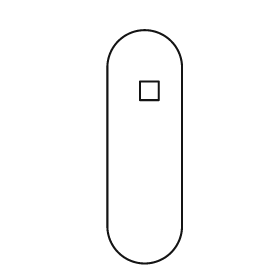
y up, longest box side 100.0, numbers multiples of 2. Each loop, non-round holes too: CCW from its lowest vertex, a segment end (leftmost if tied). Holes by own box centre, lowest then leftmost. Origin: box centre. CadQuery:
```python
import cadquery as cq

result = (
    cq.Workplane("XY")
    .moveTo(-16.0, -34.0)
    .threePointArc((0.0, -50.0), (16.0, -34.0))
    .lineTo(16.0, 34.0)
    .threePointArc((0.0, 50.0), (-16.0, 34.0))
    .close()
    .moveTo(-2.0, 20.0)
    .lineTo(6.0, 20.0)
    .lineTo(6.0, 28.0)
    .lineTo(-2.0, 28.0)
    .close()
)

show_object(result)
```